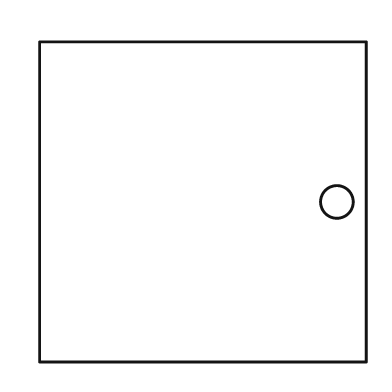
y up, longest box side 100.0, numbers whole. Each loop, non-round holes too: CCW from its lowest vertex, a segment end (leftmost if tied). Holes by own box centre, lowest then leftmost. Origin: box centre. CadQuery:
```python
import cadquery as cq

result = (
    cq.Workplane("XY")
    .moveTo(-50.0, -49.0)
    .lineTo(50.0, -49.0)
    .lineTo(50.0, 49.0)
    .lineTo(-50.0, 49.0)
    .close()
    .moveTo(41.0, 0.0)
    .circle(5.0)
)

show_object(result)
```